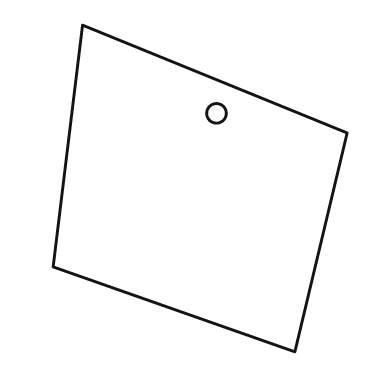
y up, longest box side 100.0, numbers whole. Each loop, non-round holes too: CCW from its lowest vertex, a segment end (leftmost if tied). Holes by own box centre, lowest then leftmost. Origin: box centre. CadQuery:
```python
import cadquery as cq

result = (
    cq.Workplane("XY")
    .moveTo(29.0, -50.0)
    .lineTo(45.0, 17.0)
    .lineTo(-36.0, 50.0)
    .lineTo(-45.0, -24.0)
    .close()
    .moveTo(5.0, 23.0)
    .circle(3.0)
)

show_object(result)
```